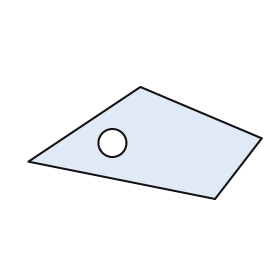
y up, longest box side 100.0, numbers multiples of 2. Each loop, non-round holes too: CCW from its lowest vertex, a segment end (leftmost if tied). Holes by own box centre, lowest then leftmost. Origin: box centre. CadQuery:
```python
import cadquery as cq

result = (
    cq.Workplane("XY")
    .moveTo(30.0, -24.0)
    .lineTo(50.0, 2.0)
    .lineTo(-2.0, 24.0)
    .lineTo(-50.0, -8.0)
    .close()
    .moveTo(-14.0, 0.0)
    .circle(6.0)
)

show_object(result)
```